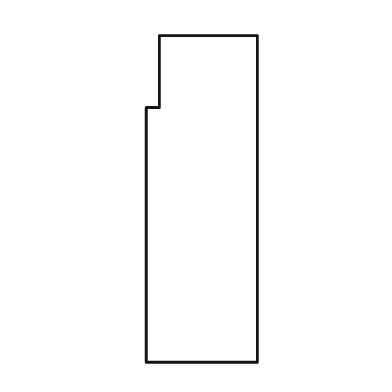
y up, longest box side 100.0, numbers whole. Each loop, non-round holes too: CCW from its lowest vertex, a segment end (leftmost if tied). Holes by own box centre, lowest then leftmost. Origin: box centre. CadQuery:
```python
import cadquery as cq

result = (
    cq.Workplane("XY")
    .moveTo(-17.0, -50.0)
    .lineTo(17.0, -50.0)
    .lineTo(17.0, 50.0)
    .lineTo(-13.0, 50.0)
    .lineTo(-13.0, 28.0)
    .lineTo(-17.0, 28.0)
    .close()
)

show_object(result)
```